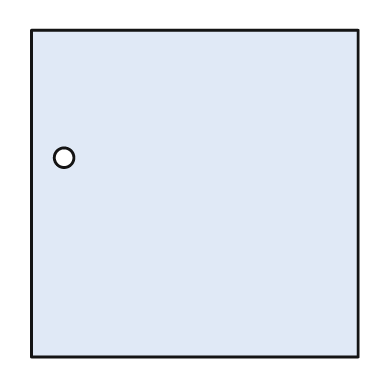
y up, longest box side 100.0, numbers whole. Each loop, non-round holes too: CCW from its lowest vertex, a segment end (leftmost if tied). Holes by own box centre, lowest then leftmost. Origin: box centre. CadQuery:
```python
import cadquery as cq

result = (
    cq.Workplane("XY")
    .moveTo(-50.0, -50.0)
    .lineTo(50.0, -50.0)
    .lineTo(50.0, 50.0)
    .lineTo(-50.0, 50.0)
    .close()
    .moveTo(-40.0, 11.0)
    .circle(3.0)
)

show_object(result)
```